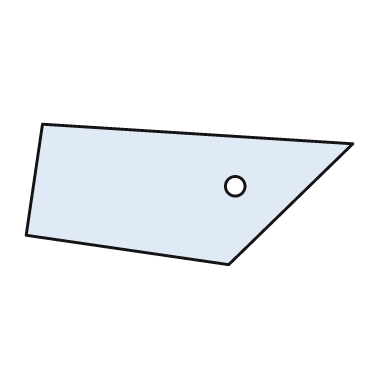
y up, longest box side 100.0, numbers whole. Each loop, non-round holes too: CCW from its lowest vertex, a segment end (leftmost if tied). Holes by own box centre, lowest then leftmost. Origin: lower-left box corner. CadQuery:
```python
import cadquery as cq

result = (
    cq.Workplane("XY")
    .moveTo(62.0, 0.0)
    .lineTo(100.0, 37.0)
    .lineTo(5.0, 43.0)
    .lineTo(0.0, 9.0)
    .close()
    .moveTo(64.0, 24.0)
    .circle(3.0)
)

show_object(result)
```